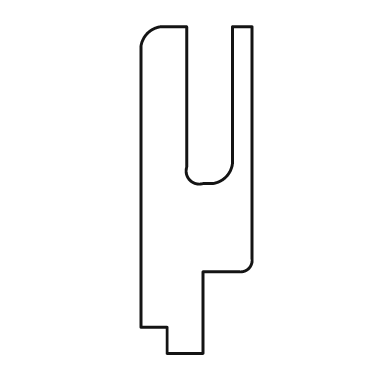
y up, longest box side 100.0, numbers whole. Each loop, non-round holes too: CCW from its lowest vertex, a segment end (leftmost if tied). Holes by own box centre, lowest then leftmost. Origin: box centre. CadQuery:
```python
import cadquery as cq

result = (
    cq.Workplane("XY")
    .moveTo(-9.0, -50.0)
    .lineTo(2.0, -50.0)
    .lineTo(2.0, -25.0)
    .lineTo(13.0, -25.0)
    .threePointArc((16.0, -24.0), (17.0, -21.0))
    .lineTo(17.0, 50.0)
    .lineTo(11.0, 50.0)
    .lineTo(11.0, 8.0)
    .threePointArc((9.0, 4.0), (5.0, 2.0))
    .lineTo(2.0, 2.0)
    .threePointArc((-2.0, 3.0), (-3.0, 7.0))
    .lineTo(-3.0, 50.0)
    .lineTo(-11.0, 50.0)
    .threePointArc((-15.0, 48.0), (-17.0, 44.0))
    .lineTo(-17.0, -42.0)
    .lineTo(-9.0, -42.0)
    .close()
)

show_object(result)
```